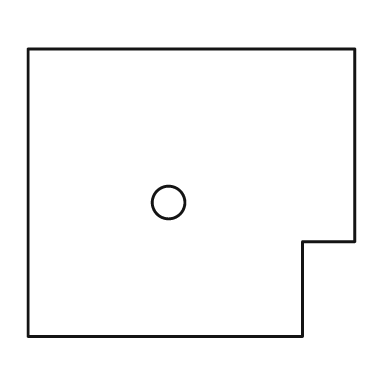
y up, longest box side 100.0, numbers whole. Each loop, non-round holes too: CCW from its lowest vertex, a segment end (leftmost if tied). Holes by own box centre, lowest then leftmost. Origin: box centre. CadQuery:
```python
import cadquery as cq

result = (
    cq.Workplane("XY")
    .moveTo(-50.0, -44.0)
    .lineTo(34.0, -44.0)
    .lineTo(34.0, -15.0)
    .lineTo(50.0, -15.0)
    .lineTo(50.0, 44.0)
    .lineTo(-50.0, 44.0)
    .close()
    .moveTo(-7.0, -3.0)
    .circle(5.0)
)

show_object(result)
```